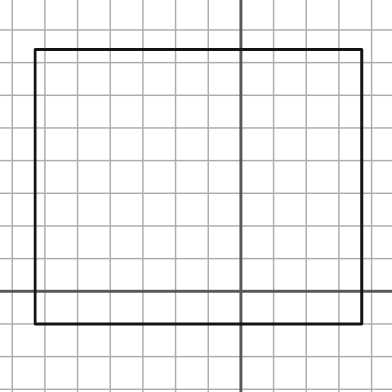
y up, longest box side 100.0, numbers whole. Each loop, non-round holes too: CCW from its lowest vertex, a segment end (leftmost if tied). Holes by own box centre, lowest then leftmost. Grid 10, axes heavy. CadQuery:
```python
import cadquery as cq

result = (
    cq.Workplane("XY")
    .moveTo(-63.0, -10.0)
    .lineTo(37.0, -10.0)
    .lineTo(37.0, 74.0)
    .lineTo(-63.0, 74.0)
    .close()
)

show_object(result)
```